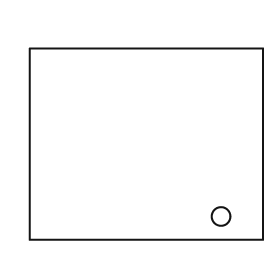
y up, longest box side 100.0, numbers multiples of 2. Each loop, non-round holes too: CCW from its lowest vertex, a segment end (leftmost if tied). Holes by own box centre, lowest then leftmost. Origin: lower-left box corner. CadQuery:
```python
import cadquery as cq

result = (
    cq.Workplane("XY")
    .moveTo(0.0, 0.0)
    .lineTo(100.0, 0.0)
    .lineTo(100.0, 82.0)
    .lineTo(0.0, 82.0)
    .close()
    .moveTo(82.0, 10.0)
    .circle(4.0)
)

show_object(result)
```